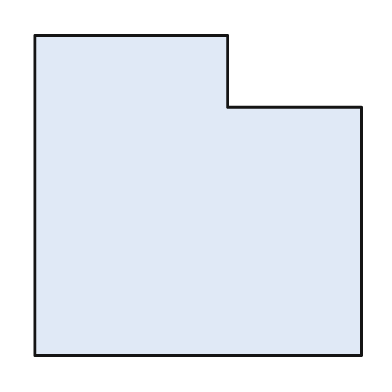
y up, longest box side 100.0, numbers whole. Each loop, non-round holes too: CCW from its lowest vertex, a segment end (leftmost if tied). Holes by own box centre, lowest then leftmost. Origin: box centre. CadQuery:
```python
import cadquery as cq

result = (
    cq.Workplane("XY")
    .moveTo(-50.0, -49.0)
    .lineTo(50.0, -49.0)
    .lineTo(50.0, 27.0)
    .lineTo(9.0, 27.0)
    .lineTo(9.0, 49.0)
    .lineTo(-50.0, 49.0)
    .close()
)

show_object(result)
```